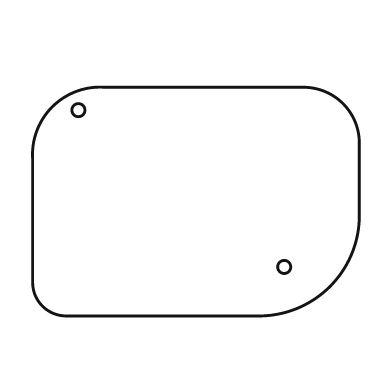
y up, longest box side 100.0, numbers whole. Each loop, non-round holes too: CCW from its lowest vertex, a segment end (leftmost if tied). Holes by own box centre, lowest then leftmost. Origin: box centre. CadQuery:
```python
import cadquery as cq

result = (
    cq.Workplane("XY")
    .moveTo(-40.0, -35.0)
    .lineTo(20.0, -35.0)
    .threePointArc((41.0, -26.0), (50.0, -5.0))
    .lineTo(50.0, 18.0)
    .threePointArc((45.0, 30.0), (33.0, 35.0))
    .lineTo(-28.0, 35.0)
    .threePointArc((-44.0, 29.0), (-50.0, 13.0))
    .lineTo(-50.0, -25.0)
    .threePointArc((-47.0, -32.0), (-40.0, -35.0))
    .close()
    .moveTo(27.0, -20.0)
    .circle(2.0)
    .moveTo(-36.0, 28.0)
    .circle(2.0)
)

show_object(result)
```